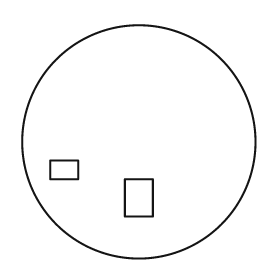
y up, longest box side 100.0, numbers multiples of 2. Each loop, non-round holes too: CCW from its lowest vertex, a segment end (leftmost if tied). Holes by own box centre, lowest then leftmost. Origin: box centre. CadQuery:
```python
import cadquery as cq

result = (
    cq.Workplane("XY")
    .moveTo(0.0, 0.0)
    .circle(50.0)
    .moveTo(-6.0, -32.0)
    .lineTo(6.0, -32.0)
    .lineTo(6.0, -16.0)
    .lineTo(-6.0, -16.0)
    .close()
    .moveTo(-38.0, -16.0)
    .lineTo(-26.0, -16.0)
    .lineTo(-26.0, -8.0)
    .lineTo(-38.0, -8.0)
    .close()
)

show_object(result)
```